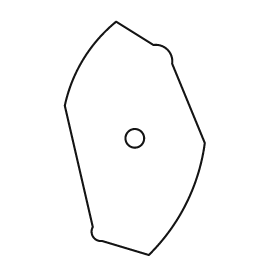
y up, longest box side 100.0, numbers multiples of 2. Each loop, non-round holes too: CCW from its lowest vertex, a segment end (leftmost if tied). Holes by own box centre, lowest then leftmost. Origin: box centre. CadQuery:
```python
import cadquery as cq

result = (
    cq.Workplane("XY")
    .moveTo(6.0, -50.0)
    .threePointArc((22.0, -28.0), (30.0, -2.0))
    .lineTo(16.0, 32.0)
    .threePointArc((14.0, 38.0), (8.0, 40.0))
    .lineTo(-8.0, 50.0)
    .threePointArc((-22.0, 34.0), (-30.0, 14.0))
    .lineTo(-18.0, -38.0)
    .threePointArc((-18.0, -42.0), (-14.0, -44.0))
    .close()
    .moveTo(0.0, 0.0)
    .circle(4.0)
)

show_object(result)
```